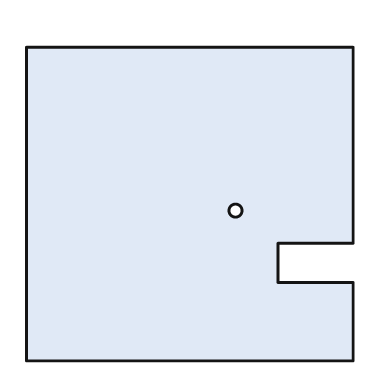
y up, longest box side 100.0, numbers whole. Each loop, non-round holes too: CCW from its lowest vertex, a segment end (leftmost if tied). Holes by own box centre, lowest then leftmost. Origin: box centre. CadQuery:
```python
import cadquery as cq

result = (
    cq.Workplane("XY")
    .moveTo(-50.0, -48.0)
    .lineTo(50.0, -48.0)
    .lineTo(50.0, -24.0)
    .lineTo(27.0, -24.0)
    .lineTo(27.0, -12.0)
    .lineTo(50.0, -12.0)
    .lineTo(50.0, 48.0)
    .lineTo(-50.0, 48.0)
    .close()
    .moveTo(14.0, -2.0)
    .circle(2.0)
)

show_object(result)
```